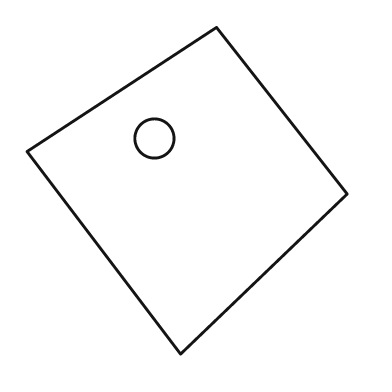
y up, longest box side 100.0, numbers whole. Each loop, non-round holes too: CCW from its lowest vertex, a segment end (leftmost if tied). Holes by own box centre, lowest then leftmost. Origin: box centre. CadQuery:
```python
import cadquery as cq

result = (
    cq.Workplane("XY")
    .moveTo(-2.0, -50.0)
    .lineTo(49.0, -1.0)
    .lineTo(9.0, 50.0)
    .lineTo(-49.0, 12.0)
    .close()
    .moveTo(-10.0, 16.0)
    .circle(6.0)
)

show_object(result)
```